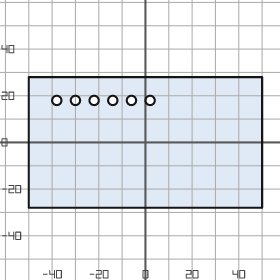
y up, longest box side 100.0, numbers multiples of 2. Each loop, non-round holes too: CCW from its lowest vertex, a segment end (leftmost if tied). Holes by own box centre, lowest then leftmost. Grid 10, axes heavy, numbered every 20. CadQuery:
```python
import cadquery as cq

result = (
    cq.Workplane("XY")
    .moveTo(-50.0, -28.0)
    .lineTo(50.0, -28.0)
    .lineTo(50.0, 28.0)
    .lineTo(-50.0, 28.0)
    .close()
    .moveTo(-38.0, 18.0)
    .circle(2.0)
    .moveTo(-30.0, 18.0)
    .circle(2.0)
    .moveTo(-22.0, 18.0)
    .circle(2.0)
    .moveTo(-14.0, 18.0)
    .circle(2.0)
    .moveTo(-6.0, 18.0)
    .circle(2.0)
    .moveTo(2.0, 18.0)
    .circle(2.0)
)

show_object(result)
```